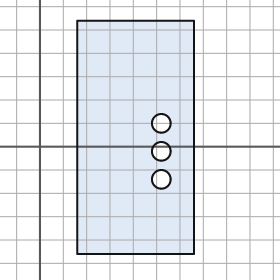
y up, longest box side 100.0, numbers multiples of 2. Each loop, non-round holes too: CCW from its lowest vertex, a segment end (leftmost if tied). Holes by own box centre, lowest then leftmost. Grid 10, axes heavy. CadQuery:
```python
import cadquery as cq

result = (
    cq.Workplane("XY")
    .moveTo(16.0, -46.0)
    .lineTo(66.0, -46.0)
    .lineTo(66.0, 54.0)
    .lineTo(16.0, 54.0)
    .close()
    .moveTo(52.0, -14.0)
    .circle(4.0)
    .moveTo(52.0, -2.0)
    .circle(4.0)
    .moveTo(52.0, 10.0)
    .circle(4.0)
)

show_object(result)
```